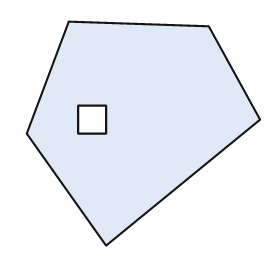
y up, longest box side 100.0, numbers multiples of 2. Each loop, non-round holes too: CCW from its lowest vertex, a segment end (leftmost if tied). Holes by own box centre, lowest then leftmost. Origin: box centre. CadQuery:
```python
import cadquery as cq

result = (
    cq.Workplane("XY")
    .moveTo(-16.0, -48.0)
    .lineTo(50.0, 6.0)
    .lineTo(28.0, 46.0)
    .lineTo(-32.0, 48.0)
    .lineTo(-50.0, 0.0)
    .close()
    .moveTo(-28.0, 0.0)
    .lineTo(-16.0, 0.0)
    .lineTo(-16.0, 12.0)
    .lineTo(-28.0, 12.0)
    .close()
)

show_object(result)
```